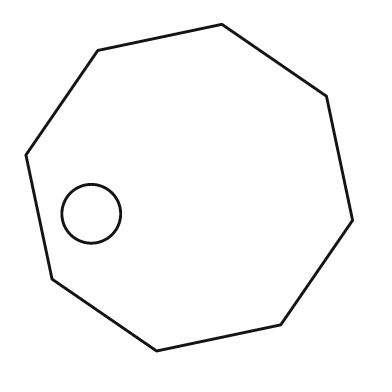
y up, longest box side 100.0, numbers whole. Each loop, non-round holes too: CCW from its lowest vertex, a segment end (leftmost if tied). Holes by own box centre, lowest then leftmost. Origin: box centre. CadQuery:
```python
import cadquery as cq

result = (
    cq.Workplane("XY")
    .moveTo(-10.0, -50.0)
    .lineTo(28.0, -42.0)
    .lineTo(50.0, -10.0)
    .lineTo(42.0, 28.0)
    .lineTo(10.0, 50.0)
    .lineTo(-28.0, 42.0)
    .lineTo(-50.0, 10.0)
    .lineTo(-42.0, -28.0)
    .close()
    .moveTo(-30.0, -8.0)
    .circle(9.0)
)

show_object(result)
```